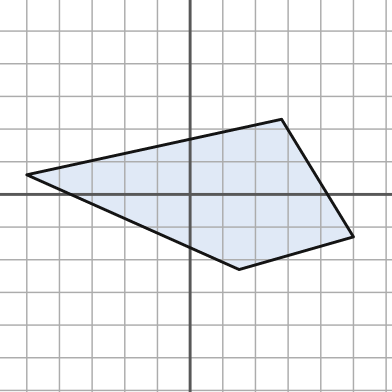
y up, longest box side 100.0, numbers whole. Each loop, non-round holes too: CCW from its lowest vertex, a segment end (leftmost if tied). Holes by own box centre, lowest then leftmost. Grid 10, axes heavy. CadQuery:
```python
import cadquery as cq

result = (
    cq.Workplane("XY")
    .moveTo(15.0, -23.0)
    .lineTo(50.0, -13.0)
    .lineTo(28.0, 23.0)
    .lineTo(-50.0, 6.0)
    .close()
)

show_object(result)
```